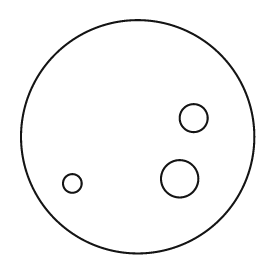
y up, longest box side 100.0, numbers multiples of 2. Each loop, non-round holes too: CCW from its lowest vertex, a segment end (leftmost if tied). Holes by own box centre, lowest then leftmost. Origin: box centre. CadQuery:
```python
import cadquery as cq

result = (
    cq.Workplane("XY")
    .moveTo(0.0, 0.0)
    .circle(50.0)
    .moveTo(-28.0, -20.0)
    .circle(4.0)
    .moveTo(18.0, -18.0)
    .circle(8.0)
    .moveTo(24.0, 8.0)
    .circle(6.0)
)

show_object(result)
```